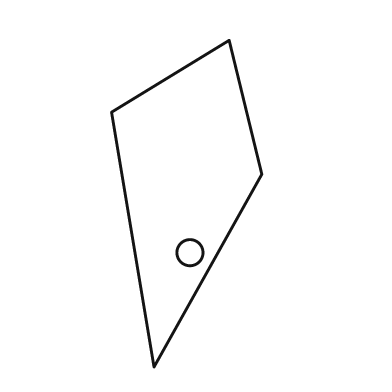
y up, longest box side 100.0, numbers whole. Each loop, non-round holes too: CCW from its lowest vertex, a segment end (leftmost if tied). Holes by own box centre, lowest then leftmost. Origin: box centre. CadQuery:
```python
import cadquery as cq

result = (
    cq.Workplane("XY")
    .moveTo(-10.0, -50.0)
    .lineTo(23.0, 9.0)
    .lineTo(13.0, 50.0)
    .lineTo(-23.0, 28.0)
    .close()
    .moveTo(1.0, -15.0)
    .circle(4.0)
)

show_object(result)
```